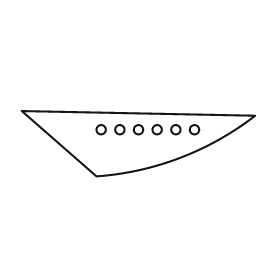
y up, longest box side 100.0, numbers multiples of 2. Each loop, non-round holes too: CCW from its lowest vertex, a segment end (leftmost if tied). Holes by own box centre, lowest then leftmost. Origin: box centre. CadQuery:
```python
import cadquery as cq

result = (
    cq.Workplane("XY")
    .moveTo(-18.0, -14.0)
    .threePointArc((18.0, -6.0), (50.0, 12.0))
    .lineTo(-50.0, 14.0)
    .close()
    .moveTo(-16.0, 6.0)
    .circle(2.0)
    .moveTo(-8.0, 6.0)
    .circle(2.0)
    .moveTo(0.0, 6.0)
    .circle(2.0)
    .moveTo(8.0, 6.0)
    .circle(2.0)
    .moveTo(16.0, 6.0)
    .circle(2.0)
    .moveTo(24.0, 6.0)
    .circle(2.0)
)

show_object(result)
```